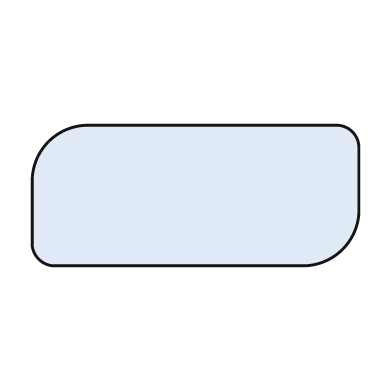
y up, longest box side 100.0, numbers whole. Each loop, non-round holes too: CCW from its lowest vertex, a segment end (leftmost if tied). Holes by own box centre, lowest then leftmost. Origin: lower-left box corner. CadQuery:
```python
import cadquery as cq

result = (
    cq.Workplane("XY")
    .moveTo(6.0, 0.0)
    .lineTo(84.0, 0.0)
    .threePointArc((95.0, 5.0), (100.0, 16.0))
    .lineTo(100.0, 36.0)
    .threePointArc((98.0, 41.0), (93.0, 43.0))
    .lineTo(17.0, 43.0)
    .threePointArc((5.0, 38.0), (0.0, 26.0))
    .lineTo(0.0, 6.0)
    .threePointArc((2.0, 2.0), (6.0, 0.0))
    .close()
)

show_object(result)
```